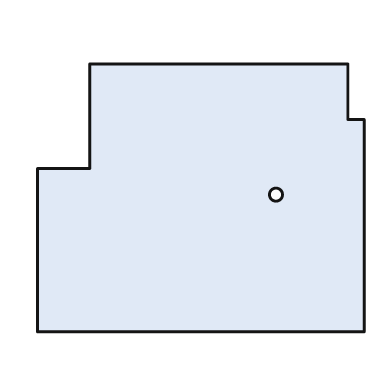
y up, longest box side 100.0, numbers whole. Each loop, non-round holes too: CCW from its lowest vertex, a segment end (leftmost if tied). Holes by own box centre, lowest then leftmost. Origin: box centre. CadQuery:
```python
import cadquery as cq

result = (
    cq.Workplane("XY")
    .moveTo(-50.0, -41.0)
    .lineTo(50.0, -41.0)
    .lineTo(50.0, 24.0)
    .lineTo(45.0, 24.0)
    .lineTo(45.0, 41.0)
    .lineTo(-34.0, 41.0)
    .lineTo(-34.0, 9.0)
    .lineTo(-50.0, 9.0)
    .close()
    .moveTo(23.0, 1.0)
    .circle(2.0)
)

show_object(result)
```